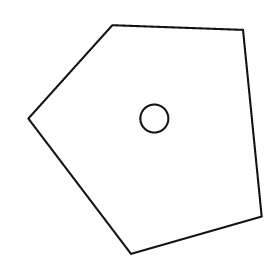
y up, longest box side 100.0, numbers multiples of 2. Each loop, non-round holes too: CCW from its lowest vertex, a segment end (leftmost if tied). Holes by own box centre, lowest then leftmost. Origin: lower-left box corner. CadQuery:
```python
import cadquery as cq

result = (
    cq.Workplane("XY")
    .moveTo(44.0, 0.0)
    .lineTo(100.0, 16.0)
    .lineTo(92.0, 96.0)
    .lineTo(36.0, 98.0)
    .lineTo(0.0, 58.0)
    .close()
    .moveTo(54.0, 58.0)
    .circle(6.0)
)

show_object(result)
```